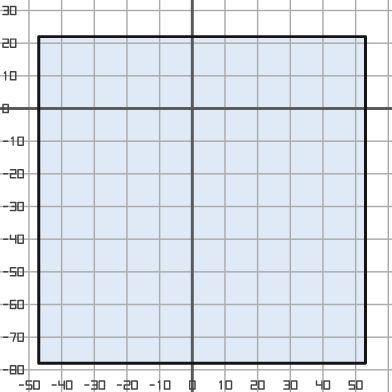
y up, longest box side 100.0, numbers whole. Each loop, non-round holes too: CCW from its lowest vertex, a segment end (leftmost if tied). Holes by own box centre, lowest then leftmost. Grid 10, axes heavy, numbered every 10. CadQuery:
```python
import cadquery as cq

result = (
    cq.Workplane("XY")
    .moveTo(-47.0, -78.0)
    .lineTo(53.0, -78.0)
    .lineTo(53.0, 22.0)
    .lineTo(-47.0, 22.0)
    .close()
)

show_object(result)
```